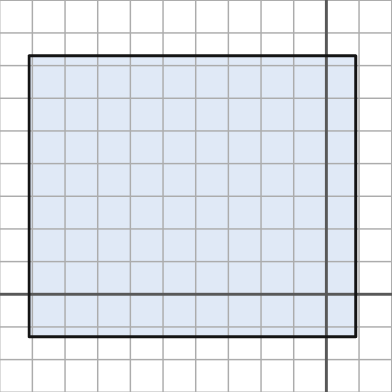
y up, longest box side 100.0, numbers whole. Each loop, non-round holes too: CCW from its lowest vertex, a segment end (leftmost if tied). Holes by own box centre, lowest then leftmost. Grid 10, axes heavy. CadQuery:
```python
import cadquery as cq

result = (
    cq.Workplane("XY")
    .moveTo(-91.0, -13.0)
    .lineTo(9.0, -13.0)
    .lineTo(9.0, 73.0)
    .lineTo(-91.0, 73.0)
    .close()
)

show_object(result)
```